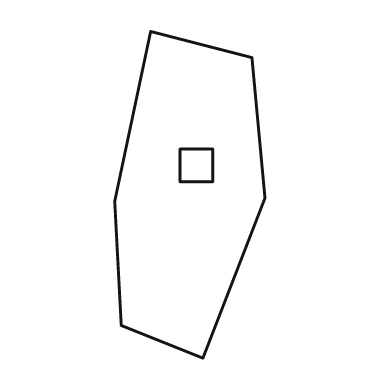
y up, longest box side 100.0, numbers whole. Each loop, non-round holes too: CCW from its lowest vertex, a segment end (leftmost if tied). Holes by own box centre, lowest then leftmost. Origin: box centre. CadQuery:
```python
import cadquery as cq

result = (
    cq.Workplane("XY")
    .moveTo(4.0, -50.0)
    .lineTo(23.0, -1.0)
    .lineTo(19.0, 42.0)
    .lineTo(-12.0, 50.0)
    .lineTo(-23.0, -2.0)
    .lineTo(-21.0, -40.0)
    .close()
    .moveTo(-3.0, 4.0)
    .lineTo(7.0, 4.0)
    .lineTo(7.0, 14.0)
    .lineTo(-3.0, 14.0)
    .close()
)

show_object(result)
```